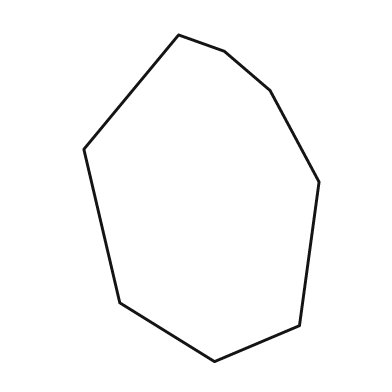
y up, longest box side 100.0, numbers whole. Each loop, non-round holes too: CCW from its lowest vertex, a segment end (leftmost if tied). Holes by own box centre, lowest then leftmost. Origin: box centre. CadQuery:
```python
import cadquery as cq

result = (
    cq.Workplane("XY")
    .moveTo(4.0, -50.0)
    .lineTo(30.0, -39.0)
    .lineTo(36.0, 5.0)
    .lineTo(21.0, 33.0)
    .lineTo(7.0, 45.0)
    .lineTo(-7.0, 50.0)
    .lineTo(-36.0, 15.0)
    .lineTo(-25.0, -32.0)
    .close()
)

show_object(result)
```